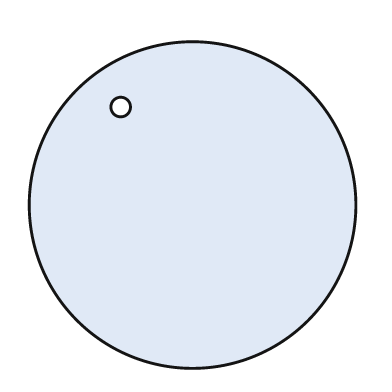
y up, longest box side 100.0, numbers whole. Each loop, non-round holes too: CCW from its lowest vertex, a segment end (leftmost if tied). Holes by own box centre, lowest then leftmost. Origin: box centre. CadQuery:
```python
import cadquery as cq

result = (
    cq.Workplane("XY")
    .moveTo(0.0, 0.0)
    .circle(50.0)
    .moveTo(-22.0, 30.0)
    .circle(3.0)
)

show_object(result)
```